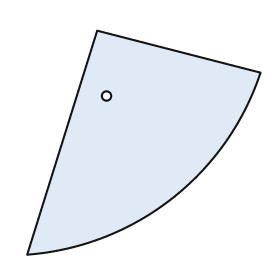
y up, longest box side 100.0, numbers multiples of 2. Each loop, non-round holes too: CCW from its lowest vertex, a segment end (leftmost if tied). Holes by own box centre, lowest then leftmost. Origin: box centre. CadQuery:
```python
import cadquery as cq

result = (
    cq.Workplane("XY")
    .moveTo(-50.0, -48.0)
    .threePointArc((12.0, -24.0), (50.0, 30.0))
    .lineTo(-20.0, 48.0)
    .close()
    .moveTo(-16.0, 20.0)
    .circle(2.0)
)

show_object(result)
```